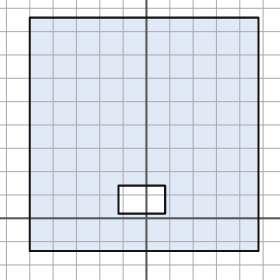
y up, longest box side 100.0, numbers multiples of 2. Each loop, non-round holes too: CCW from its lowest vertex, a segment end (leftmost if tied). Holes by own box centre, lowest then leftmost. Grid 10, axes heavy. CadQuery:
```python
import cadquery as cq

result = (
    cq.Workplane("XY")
    .moveTo(-50.0, -14.0)
    .lineTo(48.0, -14.0)
    .lineTo(48.0, 86.0)
    .lineTo(-50.0, 86.0)
    .close()
    .moveTo(-12.0, 2.0)
    .lineTo(8.0, 2.0)
    .lineTo(8.0, 14.0)
    .lineTo(-12.0, 14.0)
    .close()
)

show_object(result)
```